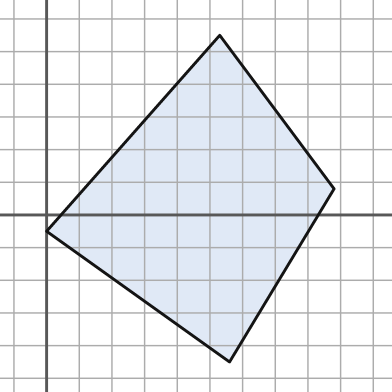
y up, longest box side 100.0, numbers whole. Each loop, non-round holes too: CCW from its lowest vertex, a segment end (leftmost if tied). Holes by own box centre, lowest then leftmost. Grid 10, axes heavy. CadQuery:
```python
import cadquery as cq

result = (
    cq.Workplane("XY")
    .moveTo(56.0, -45.0)
    .lineTo(88.0, 8.0)
    .lineTo(53.0, 55.0)
    .lineTo(0.0, -5.0)
    .close()
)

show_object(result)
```